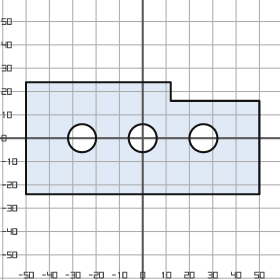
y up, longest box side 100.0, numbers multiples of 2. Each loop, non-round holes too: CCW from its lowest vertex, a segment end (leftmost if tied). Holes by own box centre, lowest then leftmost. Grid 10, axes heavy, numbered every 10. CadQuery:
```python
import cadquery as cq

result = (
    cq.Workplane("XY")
    .moveTo(-50.0, -24.0)
    .lineTo(50.0, -24.0)
    .lineTo(50.0, 16.0)
    .lineTo(12.0, 16.0)
    .lineTo(12.0, 24.0)
    .lineTo(-50.0, 24.0)
    .close()
    .moveTo(-26.0, 0.0)
    .circle(6.0)
    .moveTo(0.0, 0.0)
    .circle(6.0)
    .moveTo(26.0, 0.0)
    .circle(6.0)
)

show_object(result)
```